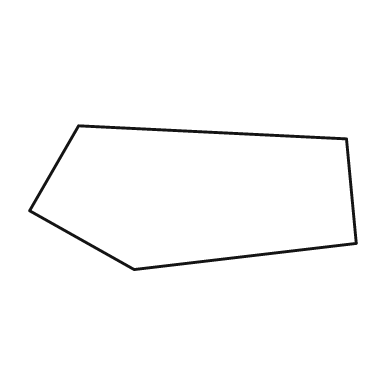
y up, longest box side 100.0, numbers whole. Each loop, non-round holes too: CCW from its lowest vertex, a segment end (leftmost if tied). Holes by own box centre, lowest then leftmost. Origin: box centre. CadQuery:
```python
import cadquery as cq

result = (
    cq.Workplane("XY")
    .moveTo(-18.0, -22.0)
    .lineTo(50.0, -14.0)
    .lineTo(47.0, 18.0)
    .lineTo(-35.0, 22.0)
    .lineTo(-50.0, -4.0)
    .close()
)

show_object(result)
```